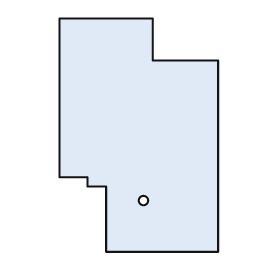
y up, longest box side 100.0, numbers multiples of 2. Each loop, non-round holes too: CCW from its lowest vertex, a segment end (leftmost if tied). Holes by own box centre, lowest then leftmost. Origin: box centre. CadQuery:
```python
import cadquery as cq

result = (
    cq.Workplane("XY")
    .moveTo(-14.0, -50.0)
    .lineTo(34.0, -50.0)
    .lineTo(34.0, 32.0)
    .lineTo(6.0, 32.0)
    .lineTo(6.0, 50.0)
    .lineTo(-34.0, 50.0)
    .lineTo(-34.0, -18.0)
    .lineTo(-22.0, -18.0)
    .lineTo(-22.0, -22.0)
    .lineTo(-14.0, -22.0)
    .close()
    .moveTo(2.0, -28.0)
    .circle(2.0)
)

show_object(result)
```